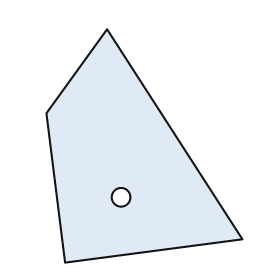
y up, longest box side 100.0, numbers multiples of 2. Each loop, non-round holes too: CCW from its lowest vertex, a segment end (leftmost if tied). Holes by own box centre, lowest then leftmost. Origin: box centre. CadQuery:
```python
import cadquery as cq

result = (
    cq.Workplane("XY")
    .moveTo(-34.0, -50.0)
    .lineTo(42.0, -40.0)
    .lineTo(-16.0, 50.0)
    .lineTo(-42.0, 14.0)
    .close()
    .moveTo(-10.0, -22.0)
    .circle(4.0)
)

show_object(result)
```